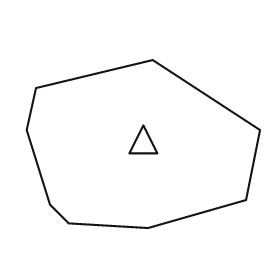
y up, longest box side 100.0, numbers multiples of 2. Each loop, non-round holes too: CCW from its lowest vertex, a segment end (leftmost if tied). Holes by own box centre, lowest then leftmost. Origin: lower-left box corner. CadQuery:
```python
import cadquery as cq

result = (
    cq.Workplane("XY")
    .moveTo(52.0, 0.0)
    .lineTo(94.0, 12.0)
    .lineTo(100.0, 42.0)
    .lineTo(54.0, 72.0)
    .lineTo(4.0, 60.0)
    .lineTo(0.0, 42.0)
    .lineTo(10.0, 10.0)
    .lineTo(18.0, 2.0)
    .close()
    .moveTo(44.0, 32.0)
    .lineTo(56.0, 32.0)
    .lineTo(50.0, 44.0)
    .close()
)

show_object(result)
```